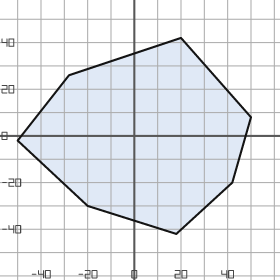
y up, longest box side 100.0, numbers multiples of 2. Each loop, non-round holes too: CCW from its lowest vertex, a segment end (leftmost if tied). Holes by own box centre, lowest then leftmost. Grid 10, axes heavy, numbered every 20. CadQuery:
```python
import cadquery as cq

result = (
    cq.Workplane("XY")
    .moveTo(18.0, -42.0)
    .lineTo(42.0, -20.0)
    .lineTo(50.0, 8.0)
    .lineTo(20.0, 42.0)
    .lineTo(-28.0, 26.0)
    .lineTo(-50.0, -2.0)
    .lineTo(-20.0, -30.0)
    .close()
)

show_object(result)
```